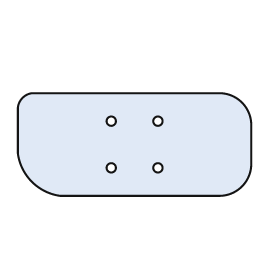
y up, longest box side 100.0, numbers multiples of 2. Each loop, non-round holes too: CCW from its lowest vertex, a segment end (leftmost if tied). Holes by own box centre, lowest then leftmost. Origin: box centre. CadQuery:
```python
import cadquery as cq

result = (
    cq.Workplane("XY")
    .moveTo(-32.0, -22.0)
    .lineTo(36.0, -22.0)
    .threePointArc((46.0, -18.0), (50.0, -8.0))
    .lineTo(50.0, 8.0)
    .threePointArc((46.0, 18.0), (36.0, 22.0))
    .lineTo(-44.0, 22.0)
    .threePointArc((-48.0, 20.0), (-50.0, 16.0))
    .lineTo(-50.0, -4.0)
    .threePointArc((-44.0, -16.0), (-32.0, -22.0))
    .close()
    .moveTo(-10.0, -10.0)
    .circle(2.0)
    .moveTo(10.0, -10.0)
    .circle(2.0)
    .moveTo(-10.0, 10.0)
    .circle(2.0)
    .moveTo(10.0, 10.0)
    .circle(2.0)
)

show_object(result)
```